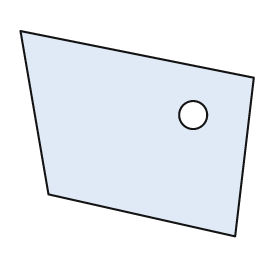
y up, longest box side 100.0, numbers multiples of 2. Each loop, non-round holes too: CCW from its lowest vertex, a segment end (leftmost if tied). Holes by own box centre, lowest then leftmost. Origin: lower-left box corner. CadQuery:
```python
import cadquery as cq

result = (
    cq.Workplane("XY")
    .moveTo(92.0, 0.0)
    .lineTo(100.0, 68.0)
    .lineTo(0.0, 88.0)
    .lineTo(12.0, 18.0)
    .close()
    .moveTo(74.0, 52.0)
    .circle(6.0)
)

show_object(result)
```